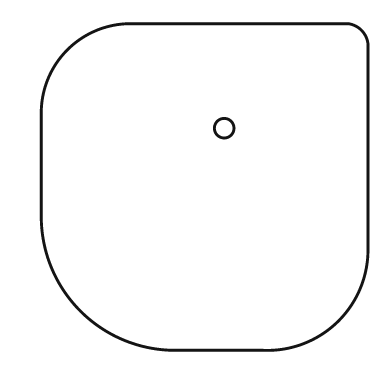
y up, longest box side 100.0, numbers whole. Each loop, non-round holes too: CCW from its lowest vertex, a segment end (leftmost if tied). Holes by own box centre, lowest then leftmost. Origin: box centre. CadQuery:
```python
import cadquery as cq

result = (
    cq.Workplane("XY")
    .moveTo(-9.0, -50.0)
    .lineTo(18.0, -50.0)
    .threePointArc((41.0, -41.0), (50.0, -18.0))
    .lineTo(50.0, 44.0)
    .threePointArc((48.0, 48.0), (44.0, 50.0))
    .lineTo(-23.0, 50.0)
    .threePointArc((-42.0, 42.0), (-50.0, 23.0))
    .lineTo(-50.0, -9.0)
    .threePointArc((-38.0, -38.0), (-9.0, -50.0))
    .close()
    .moveTo(6.0, 18.0)
    .circle(3.0)
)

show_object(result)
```